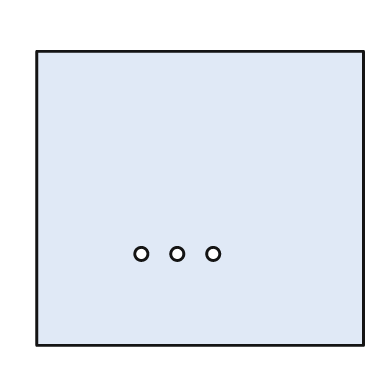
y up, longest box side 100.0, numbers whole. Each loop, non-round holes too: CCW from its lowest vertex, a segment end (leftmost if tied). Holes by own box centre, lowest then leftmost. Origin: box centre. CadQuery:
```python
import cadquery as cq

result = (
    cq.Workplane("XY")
    .moveTo(-50.0, -45.0)
    .lineTo(50.0, -45.0)
    .lineTo(50.0, 45.0)
    .lineTo(-50.0, 45.0)
    .close()
    .moveTo(-18.0, -17.0)
    .circle(2.0)
    .moveTo(-7.0, -17.0)
    .circle(2.0)
    .moveTo(4.0, -17.0)
    .circle(2.0)
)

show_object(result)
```